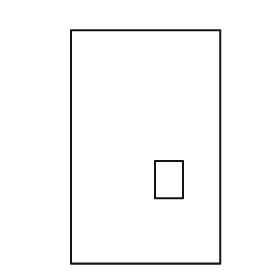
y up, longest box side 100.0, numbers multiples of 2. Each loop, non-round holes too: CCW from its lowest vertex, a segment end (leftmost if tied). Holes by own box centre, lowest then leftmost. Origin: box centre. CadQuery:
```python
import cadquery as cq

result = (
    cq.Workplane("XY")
    .moveTo(-32.0, -50.0)
    .lineTo(32.0, -50.0)
    .lineTo(32.0, 50.0)
    .lineTo(-32.0, 50.0)
    .close()
    .moveTo(4.0, -22.0)
    .lineTo(16.0, -22.0)
    .lineTo(16.0, -6.0)
    .lineTo(4.0, -6.0)
    .close()
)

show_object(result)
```